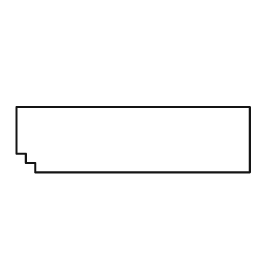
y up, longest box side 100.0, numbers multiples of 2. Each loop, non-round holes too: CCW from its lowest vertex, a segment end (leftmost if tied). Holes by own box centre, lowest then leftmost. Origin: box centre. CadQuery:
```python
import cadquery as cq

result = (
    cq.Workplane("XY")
    .moveTo(-42.0, -14.0)
    .lineTo(50.0, -14.0)
    .lineTo(50.0, 14.0)
    .lineTo(-50.0, 14.0)
    .lineTo(-50.0, -6.0)
    .lineTo(-46.0, -6.0)
    .lineTo(-46.0, -10.0)
    .lineTo(-42.0, -10.0)
    .close()
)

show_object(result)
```